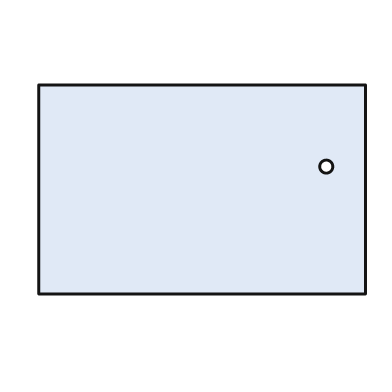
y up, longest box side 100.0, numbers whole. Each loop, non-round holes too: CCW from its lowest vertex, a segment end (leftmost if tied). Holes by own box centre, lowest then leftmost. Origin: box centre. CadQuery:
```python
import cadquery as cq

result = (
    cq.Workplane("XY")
    .moveTo(-50.0, -32.0)
    .lineTo(50.0, -32.0)
    .lineTo(50.0, 32.0)
    .lineTo(-50.0, 32.0)
    .close()
    .moveTo(38.0, 7.0)
    .circle(2.0)
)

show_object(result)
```